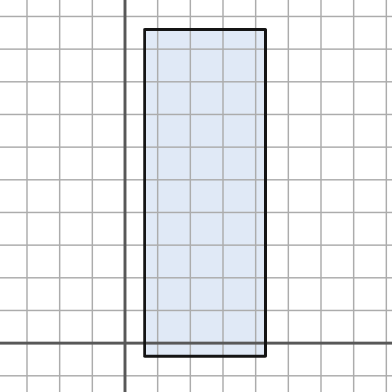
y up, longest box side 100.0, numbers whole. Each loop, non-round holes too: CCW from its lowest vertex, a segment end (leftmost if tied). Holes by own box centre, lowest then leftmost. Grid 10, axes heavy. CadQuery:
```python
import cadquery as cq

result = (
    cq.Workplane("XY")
    .moveTo(6.0, -4.0)
    .lineTo(43.0, -4.0)
    .lineTo(43.0, 96.0)
    .lineTo(6.0, 96.0)
    .close()
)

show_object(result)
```